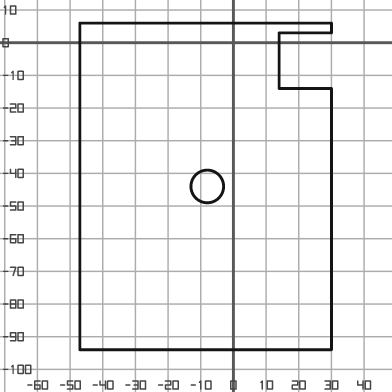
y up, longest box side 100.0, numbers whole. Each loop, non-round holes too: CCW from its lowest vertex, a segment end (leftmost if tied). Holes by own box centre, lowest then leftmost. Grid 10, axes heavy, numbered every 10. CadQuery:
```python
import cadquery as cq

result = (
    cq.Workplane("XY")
    .moveTo(-47.0, -94.0)
    .lineTo(30.0, -94.0)
    .lineTo(30.0, -14.0)
    .lineTo(14.0, -14.0)
    .lineTo(14.0, 3.0)
    .lineTo(30.0, 3.0)
    .lineTo(30.0, 6.0)
    .lineTo(-47.0, 6.0)
    .close()
    .moveTo(-8.0, -44.0)
    .circle(5.0)
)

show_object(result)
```